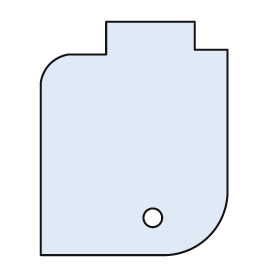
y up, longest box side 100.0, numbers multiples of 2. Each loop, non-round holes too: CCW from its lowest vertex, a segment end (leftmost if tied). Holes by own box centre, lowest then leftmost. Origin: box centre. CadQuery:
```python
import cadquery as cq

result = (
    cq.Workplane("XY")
    .moveTo(-40.0, -50.0)
    .lineTo(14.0, -50.0)
    .threePointArc((32.0, -42.0), (40.0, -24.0))
    .lineTo(40.0, 38.0)
    .lineTo(26.0, 38.0)
    .lineTo(26.0, 50.0)
    .lineTo(-12.0, 50.0)
    .lineTo(-12.0, 36.0)
    .lineTo(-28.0, 36.0)
    .threePointArc((-36.0, 32.0), (-40.0, 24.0))
    .close()
    .moveTo(8.0, -34.0)
    .circle(4.0)
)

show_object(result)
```